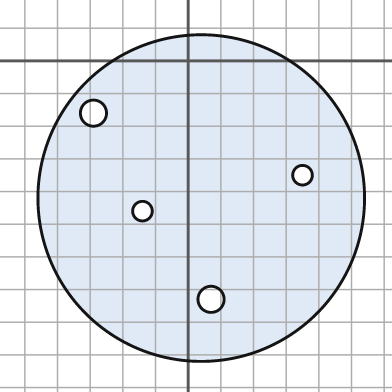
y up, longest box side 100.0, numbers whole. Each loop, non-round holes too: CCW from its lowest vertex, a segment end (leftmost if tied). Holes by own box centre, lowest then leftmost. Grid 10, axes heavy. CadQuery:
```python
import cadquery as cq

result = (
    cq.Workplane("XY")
    .moveTo(4.0, -42.0)
    .circle(50.0)
    .moveTo(7.0, -73.0)
    .circle(4.0)
    .moveTo(-14.0, -46.0)
    .circle(3.0)
    .moveTo(35.0, -35.0)
    .circle(3.0)
    .moveTo(-29.0, -16.0)
    .circle(4.0)
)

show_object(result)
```